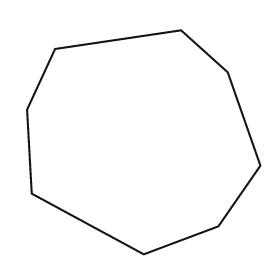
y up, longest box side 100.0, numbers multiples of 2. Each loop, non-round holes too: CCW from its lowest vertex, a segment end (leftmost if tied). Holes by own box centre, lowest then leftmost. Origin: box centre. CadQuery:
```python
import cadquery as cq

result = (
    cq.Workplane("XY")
    .moveTo(0.0, -48.0)
    .lineTo(32.0, -36.0)
    .lineTo(50.0, -10.0)
    .lineTo(36.0, 30.0)
    .lineTo(16.0, 48.0)
    .lineTo(-38.0, 40.0)
    .lineTo(-50.0, 14.0)
    .lineTo(-48.0, -22.0)
    .close()
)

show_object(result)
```